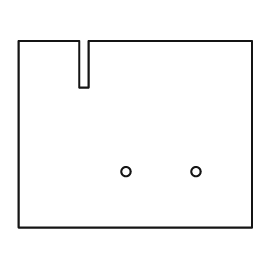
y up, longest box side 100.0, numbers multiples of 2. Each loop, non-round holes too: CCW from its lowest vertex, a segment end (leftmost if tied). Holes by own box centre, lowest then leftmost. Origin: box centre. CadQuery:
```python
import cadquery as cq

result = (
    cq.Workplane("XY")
    .moveTo(-50.0, -40.0)
    .lineTo(50.0, -40.0)
    .lineTo(50.0, 40.0)
    .lineTo(-20.0, 40.0)
    .lineTo(-20.0, 20.0)
    .lineTo(-24.0, 20.0)
    .lineTo(-24.0, 40.0)
    .lineTo(-50.0, 40.0)
    .close()
    .moveTo(-4.0, -16.0)
    .circle(2.0)
    .moveTo(26.0, -16.0)
    .circle(2.0)
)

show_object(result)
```